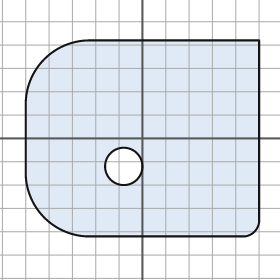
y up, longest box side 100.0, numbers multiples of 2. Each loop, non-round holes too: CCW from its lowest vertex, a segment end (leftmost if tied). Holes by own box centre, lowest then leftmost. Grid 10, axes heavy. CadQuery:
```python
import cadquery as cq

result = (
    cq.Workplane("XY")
    .moveTo(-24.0, -42.0)
    .lineTo(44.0, -42.0)
    .threePointArc((48.0, -40.0), (50.0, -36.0))
    .lineTo(50.0, 42.0)
    .lineTo(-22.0, 42.0)
    .threePointArc((-42.0, 34.0), (-50.0, 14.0))
    .lineTo(-50.0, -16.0)
    .threePointArc((-42.0, -34.0), (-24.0, -42.0))
    .close()
    .moveTo(-8.0, -12.0)
    .circle(8.0)
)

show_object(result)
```